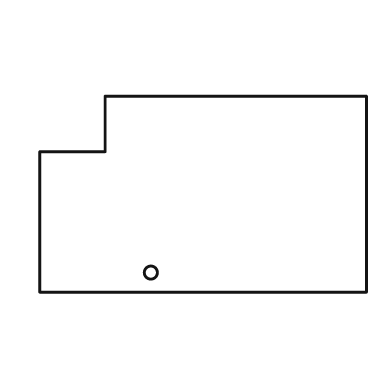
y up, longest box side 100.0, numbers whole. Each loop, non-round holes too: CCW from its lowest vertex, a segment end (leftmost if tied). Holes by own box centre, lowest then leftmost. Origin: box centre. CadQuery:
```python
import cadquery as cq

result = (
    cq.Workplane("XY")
    .moveTo(-50.0, -30.0)
    .lineTo(50.0, -30.0)
    .lineTo(50.0, 30.0)
    .lineTo(-30.0, 30.0)
    .lineTo(-30.0, 13.0)
    .lineTo(-50.0, 13.0)
    .close()
    .moveTo(-16.0, -24.0)
    .circle(2.0)
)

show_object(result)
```